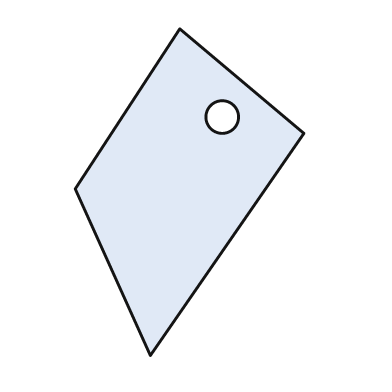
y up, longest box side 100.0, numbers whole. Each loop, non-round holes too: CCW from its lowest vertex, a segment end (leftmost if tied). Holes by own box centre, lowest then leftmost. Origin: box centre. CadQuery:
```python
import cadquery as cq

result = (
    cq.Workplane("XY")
    .moveTo(-12.0, -50.0)
    .lineTo(35.0, 18.0)
    .lineTo(-3.0, 50.0)
    .lineTo(-35.0, 1.0)
    .close()
    .moveTo(10.0, 23.0)
    .circle(5.0)
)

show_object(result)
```